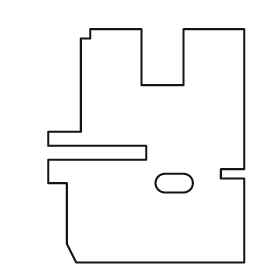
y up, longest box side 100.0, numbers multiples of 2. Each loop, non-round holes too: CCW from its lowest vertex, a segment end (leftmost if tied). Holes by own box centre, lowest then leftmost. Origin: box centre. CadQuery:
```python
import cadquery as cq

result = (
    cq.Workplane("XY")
    .moveTo(-30.0, -50.0)
    .lineTo(42.0, -50.0)
    .lineTo(42.0, -14.0)
    .lineTo(32.0, -14.0)
    .lineTo(32.0, -10.0)
    .lineTo(42.0, -10.0)
    .lineTo(42.0, 50.0)
    .lineTo(16.0, 50.0)
    .lineTo(16.0, 26.0)
    .lineTo(-2.0, 26.0)
    .lineTo(-2.0, 50.0)
    .lineTo(-24.0, 50.0)
    .lineTo(-24.0, 46.0)
    .lineTo(-28.0, 46.0)
    .lineTo(-28.0, 6.0)
    .lineTo(-42.0, 6.0)
    .lineTo(-42.0, 0.0)
    .lineTo(0.0, 0.0)
    .lineTo(0.0, -6.0)
    .lineTo(-42.0, -6.0)
    .lineTo(-42.0, -16.0)
    .lineTo(-34.0, -16.0)
    .lineTo(-34.0, -42.0)
    .close()
    .moveTo(8.0, -20.0)
    .lineTo(16.0, -20.0)
    .threePointArc((20.0, -16.0), (16.0, -12.0))
    .lineTo(8.0, -12.0)
    .threePointArc((4.0, -16.0), (8.0, -20.0))
    .close()
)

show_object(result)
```